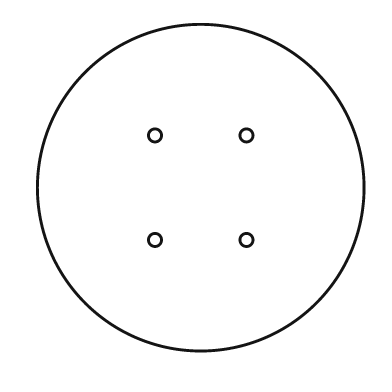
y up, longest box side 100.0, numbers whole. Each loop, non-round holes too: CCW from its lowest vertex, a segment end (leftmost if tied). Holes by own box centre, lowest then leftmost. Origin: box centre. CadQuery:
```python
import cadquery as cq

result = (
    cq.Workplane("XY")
    .moveTo(0.0, 0.0)
    .circle(50.0)
    .moveTo(-14.0, -16.0)
    .circle(2.0)
    .moveTo(14.0, -16.0)
    .circle(2.0)
    .moveTo(-14.0, 16.0)
    .circle(2.0)
    .moveTo(14.0, 16.0)
    .circle(2.0)
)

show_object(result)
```